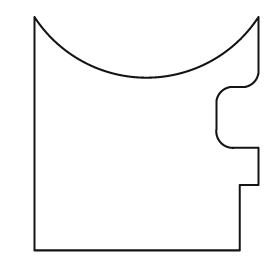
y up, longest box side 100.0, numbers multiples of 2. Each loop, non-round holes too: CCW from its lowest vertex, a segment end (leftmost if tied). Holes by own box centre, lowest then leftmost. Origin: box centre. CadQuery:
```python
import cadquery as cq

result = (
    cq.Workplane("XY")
    .moveTo(-48.0, -50.0)
    .lineTo(40.0, -50.0)
    .lineTo(40.0, -22.0)
    .lineTo(48.0, -22.0)
    .lineTo(48.0, -6.0)
    .lineTo(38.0, -6.0)
    .threePointArc((32.0, -4.0), (30.0, 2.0))
    .lineTo(30.0, 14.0)
    .threePointArc((32.0, 18.0), (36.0, 20.0))
    .lineTo(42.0, 20.0)
    .threePointArc((46.0, 22.0), (48.0, 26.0))
    .lineTo(48.0, 50.0)
    .threePointArc((0.0, 24.0), (-48.0, 50.0))
    .close()
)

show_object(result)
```